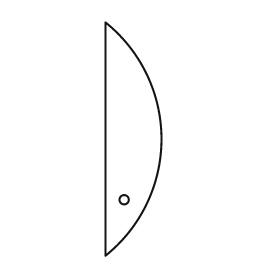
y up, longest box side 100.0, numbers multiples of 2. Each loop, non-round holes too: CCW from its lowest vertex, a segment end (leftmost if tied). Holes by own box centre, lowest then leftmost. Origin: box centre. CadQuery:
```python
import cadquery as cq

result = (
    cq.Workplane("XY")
    .moveTo(-12.0, -50.0)
    .threePointArc((12.0, 0.0), (-12.0, 50.0))
    .close()
    .moveTo(-4.0, -26.0)
    .circle(2.0)
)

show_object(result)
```